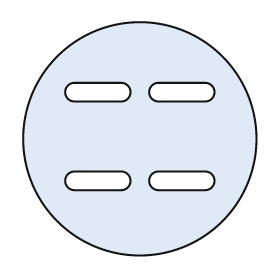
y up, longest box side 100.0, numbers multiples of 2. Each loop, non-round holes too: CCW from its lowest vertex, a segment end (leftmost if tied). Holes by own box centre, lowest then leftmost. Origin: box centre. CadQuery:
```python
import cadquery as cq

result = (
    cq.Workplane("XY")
    .moveTo(0.0, 0.0)
    .circle(50.0)
    .moveTo(-28.0, -22.0)
    .lineTo(-8.0, -22.0)
    .threePointArc((-4.0, -18.0), (-8.0, -14.0))
    .lineTo(-28.0, -14.0)
    .threePointArc((-32.0, -18.0), (-28.0, -22.0))
    .close()
    .moveTo(8.0, -22.0)
    .lineTo(28.0, -22.0)
    .threePointArc((32.0, -18.0), (28.0, -14.0))
    .lineTo(8.0, -14.0)
    .threePointArc((4.0, -18.0), (8.0, -22.0))
    .close()
    .moveTo(-28.0, 16.0)
    .lineTo(-8.0, 16.0)
    .threePointArc((-4.0, 20.0), (-8.0, 24.0))
    .lineTo(-28.0, 24.0)
    .threePointArc((-32.0, 20.0), (-28.0, 16.0))
    .close()
    .moveTo(8.0, 16.0)
    .lineTo(28.0, 16.0)
    .threePointArc((32.0, 20.0), (28.0, 24.0))
    .lineTo(8.0, 24.0)
    .threePointArc((4.0, 20.0), (8.0, 16.0))
    .close()
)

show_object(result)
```